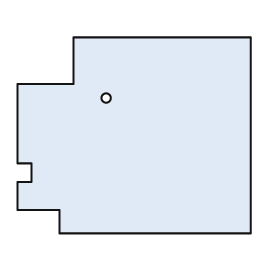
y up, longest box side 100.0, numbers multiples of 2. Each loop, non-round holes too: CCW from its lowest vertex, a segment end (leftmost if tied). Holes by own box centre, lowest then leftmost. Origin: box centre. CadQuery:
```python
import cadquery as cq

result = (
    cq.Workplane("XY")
    .moveTo(-32.0, -42.0)
    .lineTo(50.0, -42.0)
    .lineTo(50.0, 42.0)
    .lineTo(-26.0, 42.0)
    .lineTo(-26.0, 22.0)
    .lineTo(-50.0, 22.0)
    .lineTo(-50.0, -12.0)
    .lineTo(-44.0, -12.0)
    .lineTo(-44.0, -20.0)
    .lineTo(-50.0, -20.0)
    .lineTo(-50.0, -32.0)
    .lineTo(-32.0, -32.0)
    .close()
    .moveTo(-12.0, 16.0)
    .circle(2.0)
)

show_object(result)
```